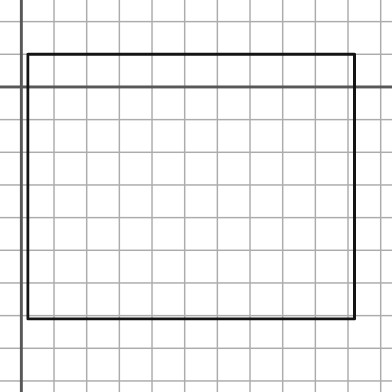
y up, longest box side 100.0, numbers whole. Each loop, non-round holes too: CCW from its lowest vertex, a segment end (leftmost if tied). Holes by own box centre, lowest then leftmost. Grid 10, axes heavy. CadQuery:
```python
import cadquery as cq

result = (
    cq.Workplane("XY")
    .moveTo(2.0, -71.0)
    .lineTo(102.0, -71.0)
    .lineTo(102.0, 10.0)
    .lineTo(2.0, 10.0)
    .close()
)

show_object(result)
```